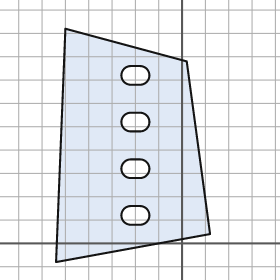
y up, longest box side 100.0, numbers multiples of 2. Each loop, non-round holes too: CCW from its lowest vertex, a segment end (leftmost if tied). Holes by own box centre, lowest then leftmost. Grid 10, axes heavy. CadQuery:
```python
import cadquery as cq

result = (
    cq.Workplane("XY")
    .moveTo(-54.0, -8.0)
    .lineTo(12.0, 4.0)
    .lineTo(2.0, 78.0)
    .lineTo(-50.0, 92.0)
    .close()
    .moveTo(-22.0, 8.0)
    .lineTo(-18.0, 8.0)
    .threePointArc((-14.0, 12.0), (-18.0, 16.0))
    .lineTo(-22.0, 16.0)
    .threePointArc((-26.0, 12.0), (-22.0, 8.0))
    .close()
    .moveTo(-22.0, 28.0)
    .lineTo(-18.0, 28.0)
    .threePointArc((-14.0, 32.0), (-18.0, 36.0))
    .lineTo(-22.0, 36.0)
    .threePointArc((-26.0, 32.0), (-22.0, 28.0))
    .close()
    .moveTo(-22.0, 48.0)
    .lineTo(-18.0, 48.0)
    .threePointArc((-14.0, 52.0), (-18.0, 56.0))
    .lineTo(-22.0, 56.0)
    .threePointArc((-26.0, 52.0), (-22.0, 48.0))
    .close()
    .moveTo(-22.0, 68.0)
    .lineTo(-18.0, 68.0)
    .threePointArc((-14.0, 72.0), (-18.0, 76.0))
    .lineTo(-22.0, 76.0)
    .threePointArc((-26.0, 72.0), (-22.0, 68.0))
    .close()
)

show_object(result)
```